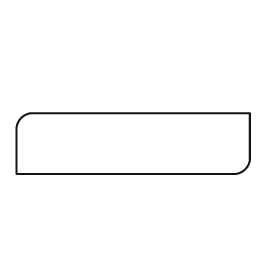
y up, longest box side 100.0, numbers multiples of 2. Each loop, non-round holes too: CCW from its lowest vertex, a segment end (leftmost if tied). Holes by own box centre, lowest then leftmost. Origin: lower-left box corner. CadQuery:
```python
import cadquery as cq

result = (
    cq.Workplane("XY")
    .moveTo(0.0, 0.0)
    .lineTo(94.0, 0.0)
    .threePointArc((98.0, 2.0), (100.0, 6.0))
    .lineTo(100.0, 26.0)
    .lineTo(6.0, 26.0)
    .threePointArc((2.0, 24.0), (0.0, 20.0))
    .close()
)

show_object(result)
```